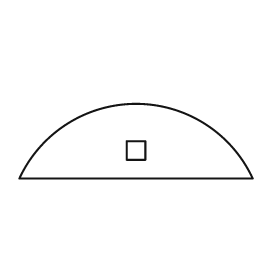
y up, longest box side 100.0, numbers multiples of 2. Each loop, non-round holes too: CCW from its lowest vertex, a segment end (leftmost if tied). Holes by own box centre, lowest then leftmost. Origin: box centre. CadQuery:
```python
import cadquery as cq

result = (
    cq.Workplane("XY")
    .moveTo(-50.0, -16.0)
    .lineTo(50.0, -16.0)
    .threePointArc((0.0, 16.0), (-50.0, -16.0))
    .close()
    .moveTo(-4.0, -8.0)
    .lineTo(4.0, -8.0)
    .lineTo(4.0, 0.0)
    .lineTo(-4.0, 0.0)
    .close()
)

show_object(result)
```